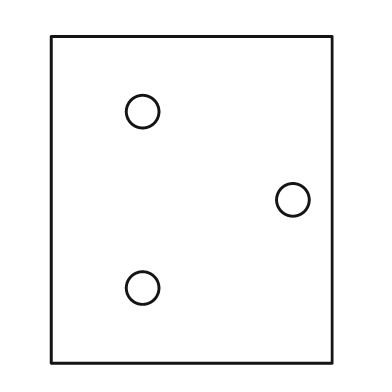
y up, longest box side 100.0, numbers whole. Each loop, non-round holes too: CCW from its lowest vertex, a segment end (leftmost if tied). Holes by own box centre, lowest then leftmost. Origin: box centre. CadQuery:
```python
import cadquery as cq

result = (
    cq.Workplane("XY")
    .moveTo(-43.0, -50.0)
    .lineTo(43.0, -50.0)
    .lineTo(43.0, 50.0)
    .lineTo(-43.0, 50.0)
    .close()
    .moveTo(-15.0, -27.0)
    .circle(5.0)
    .moveTo(31.0, 0.0)
    .circle(5.0)
    .moveTo(-15.0, 27.0)
    .circle(5.0)
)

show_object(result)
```